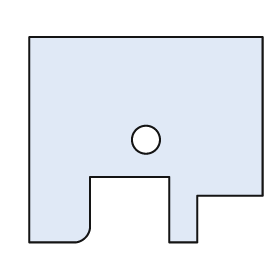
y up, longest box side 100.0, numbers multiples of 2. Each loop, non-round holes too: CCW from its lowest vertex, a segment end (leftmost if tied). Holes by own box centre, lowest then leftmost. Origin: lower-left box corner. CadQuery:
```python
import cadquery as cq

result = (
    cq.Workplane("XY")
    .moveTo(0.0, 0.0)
    .lineTo(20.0, 0.0)
    .threePointArc((24.0, 2.0), (26.0, 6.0))
    .lineTo(26.0, 28.0)
    .lineTo(60.0, 28.0)
    .lineTo(60.0, 0.0)
    .lineTo(72.0, 0.0)
    .lineTo(72.0, 20.0)
    .lineTo(100.0, 20.0)
    .lineTo(100.0, 88.0)
    .lineTo(0.0, 88.0)
    .close()
    .moveTo(50.0, 44.0)
    .circle(6.0)
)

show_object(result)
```